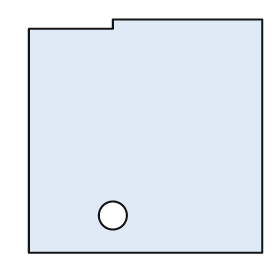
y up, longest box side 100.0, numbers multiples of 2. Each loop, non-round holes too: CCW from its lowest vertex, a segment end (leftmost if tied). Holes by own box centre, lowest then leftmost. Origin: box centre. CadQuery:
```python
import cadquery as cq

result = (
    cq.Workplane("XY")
    .moveTo(-50.0, -50.0)
    .lineTo(50.0, -50.0)
    .lineTo(50.0, 50.0)
    .lineTo(-14.0, 50.0)
    .lineTo(-14.0, 46.0)
    .lineTo(-50.0, 46.0)
    .close()
    .moveTo(-14.0, -34.0)
    .circle(6.0)
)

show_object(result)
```